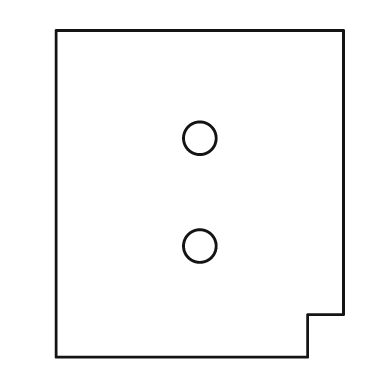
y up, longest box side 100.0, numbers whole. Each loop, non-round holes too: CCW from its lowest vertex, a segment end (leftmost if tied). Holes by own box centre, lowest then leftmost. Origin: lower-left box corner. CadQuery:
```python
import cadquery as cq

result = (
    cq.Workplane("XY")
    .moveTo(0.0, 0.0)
    .lineTo(77.0, 0.0)
    .lineTo(77.0, 13.0)
    .lineTo(88.0, 13.0)
    .lineTo(88.0, 100.0)
    .lineTo(0.0, 100.0)
    .close()
    .moveTo(44.0, 34.0)
    .circle(5.0)
    .moveTo(44.0, 67.0)
    .circle(5.0)
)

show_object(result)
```